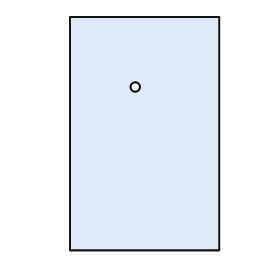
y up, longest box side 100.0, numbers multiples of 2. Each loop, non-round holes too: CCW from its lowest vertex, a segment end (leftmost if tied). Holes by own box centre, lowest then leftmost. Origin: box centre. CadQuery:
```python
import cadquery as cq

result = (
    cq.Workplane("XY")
    .moveTo(-32.0, -50.0)
    .lineTo(32.0, -50.0)
    .lineTo(32.0, 50.0)
    .lineTo(-32.0, 50.0)
    .close()
    .moveTo(-4.0, 20.0)
    .circle(2.0)
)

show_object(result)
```